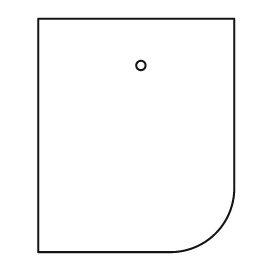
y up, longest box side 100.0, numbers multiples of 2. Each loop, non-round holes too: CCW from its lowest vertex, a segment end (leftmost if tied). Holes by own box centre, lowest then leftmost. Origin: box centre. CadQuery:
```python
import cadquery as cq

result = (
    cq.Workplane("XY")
    .moveTo(-42.0, -50.0)
    .lineTo(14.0, -50.0)
    .threePointArc((34.0, -42.0), (42.0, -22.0))
    .lineTo(42.0, 50.0)
    .lineTo(-42.0, 50.0)
    .close()
    .moveTo(2.0, 30.0)
    .circle(2.0)
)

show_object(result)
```